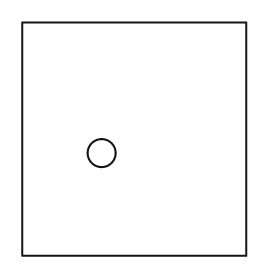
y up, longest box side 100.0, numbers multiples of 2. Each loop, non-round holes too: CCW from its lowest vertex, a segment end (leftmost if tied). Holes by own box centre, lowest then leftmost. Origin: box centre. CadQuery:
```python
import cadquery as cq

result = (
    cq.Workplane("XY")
    .moveTo(-48.0, -50.0)
    .lineTo(48.0, -50.0)
    .lineTo(48.0, 50.0)
    .lineTo(-48.0, 50.0)
    .close()
    .moveTo(-14.0, -6.0)
    .circle(6.0)
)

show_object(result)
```